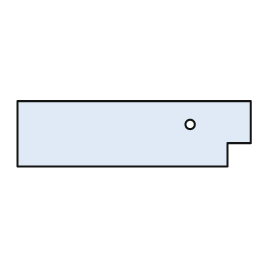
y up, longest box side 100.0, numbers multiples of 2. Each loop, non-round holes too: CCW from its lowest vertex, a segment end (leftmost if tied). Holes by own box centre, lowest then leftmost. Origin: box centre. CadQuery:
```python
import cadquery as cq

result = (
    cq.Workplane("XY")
    .moveTo(-50.0, -14.0)
    .lineTo(40.0, -14.0)
    .lineTo(40.0, -4.0)
    .lineTo(50.0, -4.0)
    .lineTo(50.0, 14.0)
    .lineTo(-50.0, 14.0)
    .close()
    .moveTo(24.0, 4.0)
    .circle(2.0)
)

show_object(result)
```